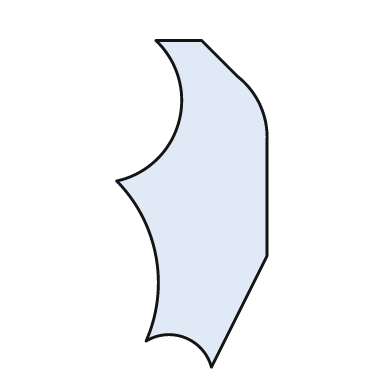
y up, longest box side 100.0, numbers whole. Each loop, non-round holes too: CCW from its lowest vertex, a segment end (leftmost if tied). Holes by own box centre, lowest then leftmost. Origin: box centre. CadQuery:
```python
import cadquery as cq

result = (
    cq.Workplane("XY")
    .moveTo(6.0, -50.0)
    .lineTo(23.0, -16.0)
    .lineTo(23.0, 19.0)
    .threePointArc((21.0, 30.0), (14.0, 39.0))
    .lineTo(3.0, 50.0)
    .lineTo(-11.0, 50.0)
    .threePointArc((-4.0, 25.0), (-23.0, 7.0))
    .threePointArc((-11.0, -16.0), (-14.0, -42.0))
    .threePointArc((-2.0, -41.0), (6.0, -50.0))
    .close()
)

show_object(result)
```